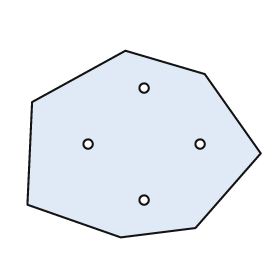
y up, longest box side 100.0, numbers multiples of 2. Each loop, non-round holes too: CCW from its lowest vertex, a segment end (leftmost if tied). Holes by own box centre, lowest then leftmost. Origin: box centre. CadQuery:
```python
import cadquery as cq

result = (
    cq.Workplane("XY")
    .moveTo(-10.0, -40.0)
    .lineTo(22.0, -36.0)
    .lineTo(50.0, -4.0)
    .lineTo(26.0, 30.0)
    .lineTo(-8.0, 40.0)
    .lineTo(-48.0, 18.0)
    .lineTo(-50.0, -26.0)
    .close()
    .moveTo(0.0, -24.0)
    .circle(2.0)
    .moveTo(-24.0, 0.0)
    .circle(2.0)
    .moveTo(24.0, 0.0)
    .circle(2.0)
    .moveTo(0.0, 24.0)
    .circle(2.0)
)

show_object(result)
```